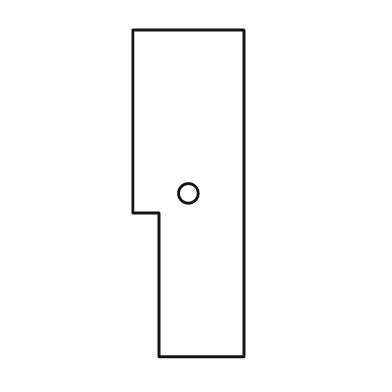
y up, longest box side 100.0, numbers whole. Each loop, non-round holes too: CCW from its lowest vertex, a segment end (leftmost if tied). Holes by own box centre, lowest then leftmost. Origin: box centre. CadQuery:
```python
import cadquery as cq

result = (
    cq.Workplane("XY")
    .moveTo(-9.0, -50.0)
    .lineTo(17.0, -50.0)
    .lineTo(17.0, 50.0)
    .lineTo(-17.0, 50.0)
    .lineTo(-17.0, -6.0)
    .lineTo(-9.0, -6.0)
    .close()
    .moveTo(0.0, 0.0)
    .circle(3.0)
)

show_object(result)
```